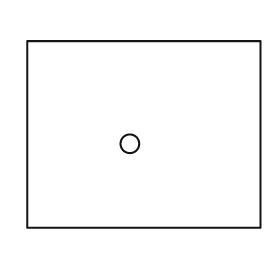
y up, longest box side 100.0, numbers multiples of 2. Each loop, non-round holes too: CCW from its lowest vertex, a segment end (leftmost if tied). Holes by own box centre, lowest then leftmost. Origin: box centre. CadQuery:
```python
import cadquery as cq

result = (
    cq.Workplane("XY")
    .moveTo(-50.0, -40.0)
    .lineTo(50.0, -40.0)
    .lineTo(50.0, 40.0)
    .lineTo(-50.0, 40.0)
    .close()
    .moveTo(-6.0, -4.0)
    .circle(4.0)
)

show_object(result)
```